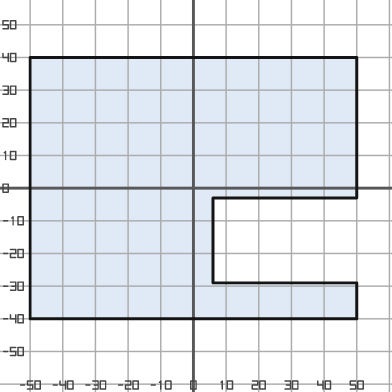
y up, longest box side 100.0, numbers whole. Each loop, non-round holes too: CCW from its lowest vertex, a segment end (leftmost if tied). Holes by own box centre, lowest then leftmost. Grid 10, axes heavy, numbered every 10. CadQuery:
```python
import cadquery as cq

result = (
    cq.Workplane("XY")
    .moveTo(-50.0, -40.0)
    .lineTo(50.0, -40.0)
    .lineTo(50.0, -29.0)
    .lineTo(6.0, -29.0)
    .lineTo(6.0, -3.0)
    .lineTo(50.0, -3.0)
    .lineTo(50.0, 40.0)
    .lineTo(-50.0, 40.0)
    .close()
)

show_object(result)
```